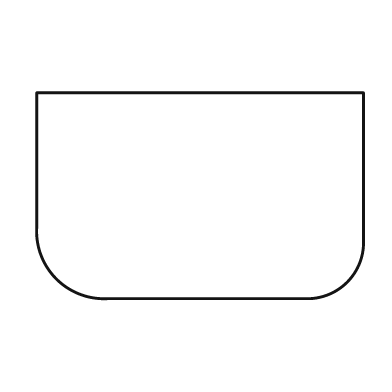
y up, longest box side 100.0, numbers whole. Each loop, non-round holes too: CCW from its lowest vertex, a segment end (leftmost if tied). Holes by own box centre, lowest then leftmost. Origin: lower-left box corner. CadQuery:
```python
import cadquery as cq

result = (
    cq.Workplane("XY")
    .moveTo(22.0, 0.0)
    .lineTo(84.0, 0.0)
    .threePointArc((95.0, 5.0), (100.0, 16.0))
    .lineTo(100.0, 63.0)
    .lineTo(0.0, 63.0)
    .lineTo(0.0, 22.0)
    .threePointArc((6.0, 6.0), (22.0, 0.0))
    .close()
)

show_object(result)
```